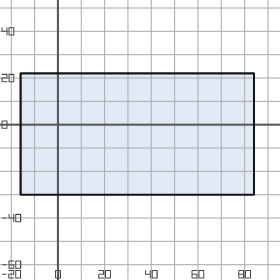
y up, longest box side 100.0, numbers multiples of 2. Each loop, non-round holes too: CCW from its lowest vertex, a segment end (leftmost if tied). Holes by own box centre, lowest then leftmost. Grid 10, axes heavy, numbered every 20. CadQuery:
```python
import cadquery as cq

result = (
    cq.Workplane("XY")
    .moveTo(-16.0, -30.0)
    .lineTo(84.0, -30.0)
    .lineTo(84.0, 22.0)
    .lineTo(-16.0, 22.0)
    .close()
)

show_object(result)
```